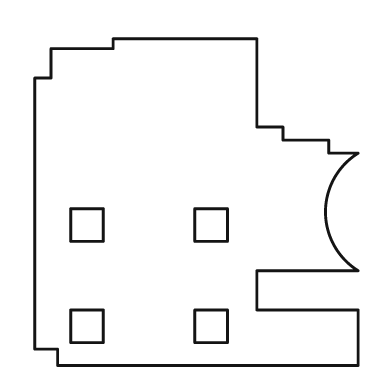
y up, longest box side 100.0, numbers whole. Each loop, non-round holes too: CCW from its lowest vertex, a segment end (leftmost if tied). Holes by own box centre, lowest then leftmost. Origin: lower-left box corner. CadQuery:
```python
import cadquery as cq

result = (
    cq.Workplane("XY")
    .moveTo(7.0, 0.0)
    .lineTo(99.0, 0.0)
    .lineTo(99.0, 17.0)
    .lineTo(68.0, 17.0)
    .lineTo(68.0, 29.0)
    .lineTo(99.0, 29.0)
    .threePointArc((89.0, 47.0), (99.0, 65.0))
    .lineTo(90.0, 65.0)
    .lineTo(90.0, 69.0)
    .lineTo(76.0, 69.0)
    .lineTo(76.0, 73.0)
    .lineTo(68.0, 73.0)
    .lineTo(68.0, 100.0)
    .lineTo(24.0, 100.0)
    .lineTo(24.0, 97.0)
    .lineTo(5.0, 97.0)
    .lineTo(5.0, 88.0)
    .lineTo(0.0, 88.0)
    .lineTo(0.0, 5.0)
    .lineTo(7.0, 5.0)
    .close()
    .moveTo(11.0, 7.0)
    .lineTo(21.0, 7.0)
    .lineTo(21.0, 17.0)
    .lineTo(11.0, 17.0)
    .close()
    .moveTo(49.0, 7.0)
    .lineTo(59.0, 7.0)
    .lineTo(59.0, 17.0)
    .lineTo(49.0, 17.0)
    .close()
    .moveTo(11.0, 38.0)
    .lineTo(21.0, 38.0)
    .lineTo(21.0, 48.0)
    .lineTo(11.0, 48.0)
    .close()
    .moveTo(49.0, 38.0)
    .lineTo(59.0, 38.0)
    .lineTo(59.0, 48.0)
    .lineTo(49.0, 48.0)
    .close()
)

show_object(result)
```